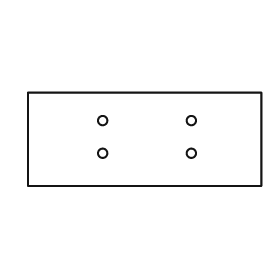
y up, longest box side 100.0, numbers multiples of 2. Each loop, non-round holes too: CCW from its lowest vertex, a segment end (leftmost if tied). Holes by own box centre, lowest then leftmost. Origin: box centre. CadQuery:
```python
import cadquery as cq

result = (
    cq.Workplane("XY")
    .moveTo(-50.0, -20.0)
    .lineTo(50.0, -20.0)
    .lineTo(50.0, 20.0)
    .lineTo(-50.0, 20.0)
    .close()
    .moveTo(-18.0, -6.0)
    .circle(2.0)
    .moveTo(20.0, -6.0)
    .circle(2.0)
    .moveTo(-18.0, 8.0)
    .circle(2.0)
    .moveTo(20.0, 8.0)
    .circle(2.0)
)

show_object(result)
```